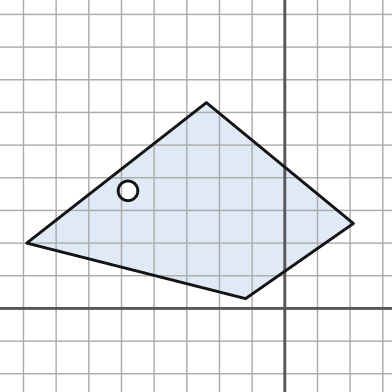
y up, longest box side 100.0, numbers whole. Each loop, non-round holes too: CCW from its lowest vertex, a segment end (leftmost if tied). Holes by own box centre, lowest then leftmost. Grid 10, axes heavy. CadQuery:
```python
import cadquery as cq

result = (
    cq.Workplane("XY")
    .moveTo(-12.0, 3.0)
    .lineTo(21.0, 26.0)
    .lineTo(-24.0, 63.0)
    .lineTo(-79.0, 20.0)
    .close()
    .moveTo(-48.0, 36.0)
    .circle(3.0)
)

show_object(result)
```